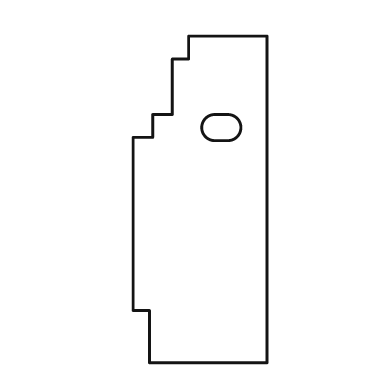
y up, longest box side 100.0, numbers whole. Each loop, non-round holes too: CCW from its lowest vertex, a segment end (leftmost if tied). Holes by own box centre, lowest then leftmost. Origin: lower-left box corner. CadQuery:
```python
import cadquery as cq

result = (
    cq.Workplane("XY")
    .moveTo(5.0, 0.0)
    .lineTo(41.0, 0.0)
    .lineTo(41.0, 100.0)
    .lineTo(17.0, 100.0)
    .lineTo(17.0, 93.0)
    .lineTo(12.0, 93.0)
    .lineTo(12.0, 76.0)
    .lineTo(6.0, 76.0)
    .lineTo(6.0, 69.0)
    .lineTo(0.0, 69.0)
    .lineTo(0.0, 16.0)
    .lineTo(5.0, 16.0)
    .close()
    .moveTo(25.0, 68.0)
    .lineTo(29.0, 68.0)
    .threePointArc((33.0, 72.0), (29.0, 76.0))
    .lineTo(25.0, 76.0)
    .threePointArc((21.0, 72.0), (25.0, 68.0))
    .close()
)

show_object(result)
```